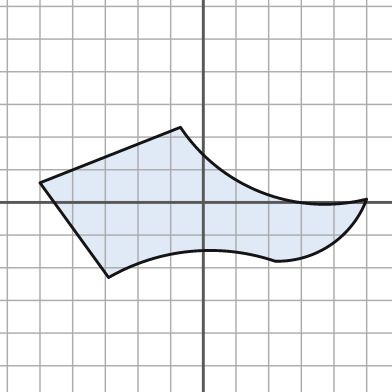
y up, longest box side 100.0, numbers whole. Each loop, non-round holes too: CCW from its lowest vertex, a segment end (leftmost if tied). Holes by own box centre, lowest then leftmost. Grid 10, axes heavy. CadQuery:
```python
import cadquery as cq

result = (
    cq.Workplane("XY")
    .moveTo(-29.0, -23.0)
    .threePointArc((-4.0, -15.0), (22.0, -18.0))
    .threePointArc((39.0, -13.0), (50.0, 1.0))
    .threePointArc((18.0, 3.0), (-7.0, 23.0))
    .lineTo(-50.0, 6.0)
    .close()
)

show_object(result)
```